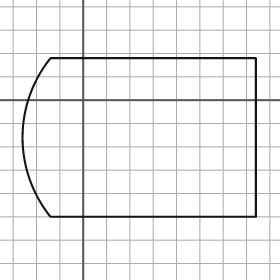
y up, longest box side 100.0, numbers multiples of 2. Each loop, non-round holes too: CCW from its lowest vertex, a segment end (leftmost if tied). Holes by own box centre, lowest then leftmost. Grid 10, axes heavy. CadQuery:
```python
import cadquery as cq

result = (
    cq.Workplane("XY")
    .moveTo(-14.0, -50.0)
    .lineTo(74.0, -50.0)
    .lineTo(74.0, 18.0)
    .lineTo(-14.0, 18.0)
    .threePointArc((-26.0, -16.0), (-14.0, -50.0))
    .close()
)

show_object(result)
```